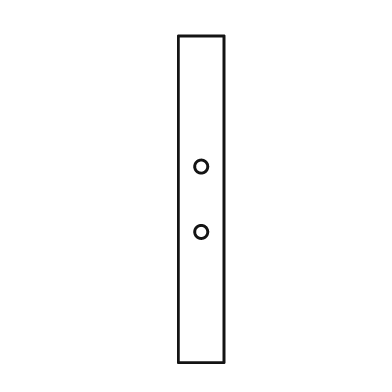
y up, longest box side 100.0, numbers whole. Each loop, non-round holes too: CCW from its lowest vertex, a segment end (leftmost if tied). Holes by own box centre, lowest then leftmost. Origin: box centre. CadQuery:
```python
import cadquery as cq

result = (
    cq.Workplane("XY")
    .moveTo(-7.0, -50.0)
    .lineTo(7.0, -50.0)
    .lineTo(7.0, 50.0)
    .lineTo(-7.0, 50.0)
    .close()
    .moveTo(0.0, -10.0)
    .circle(2.0)
    .moveTo(0.0, 10.0)
    .circle(2.0)
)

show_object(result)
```